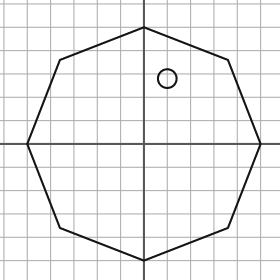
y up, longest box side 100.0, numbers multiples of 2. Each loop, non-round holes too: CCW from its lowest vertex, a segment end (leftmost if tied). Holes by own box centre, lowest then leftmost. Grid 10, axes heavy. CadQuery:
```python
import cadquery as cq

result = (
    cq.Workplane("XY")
    .moveTo(0.0, -50.0)
    .lineTo(36.0, -36.0)
    .lineTo(50.0, 0.0)
    .lineTo(36.0, 36.0)
    .lineTo(0.0, 50.0)
    .lineTo(-36.0, 36.0)
    .lineTo(-50.0, 0.0)
    .lineTo(-36.0, -36.0)
    .close()
    .moveTo(10.0, 28.0)
    .circle(4.0)
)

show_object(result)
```